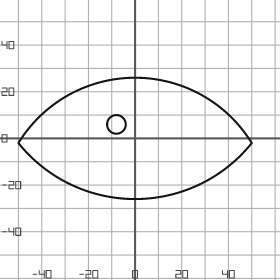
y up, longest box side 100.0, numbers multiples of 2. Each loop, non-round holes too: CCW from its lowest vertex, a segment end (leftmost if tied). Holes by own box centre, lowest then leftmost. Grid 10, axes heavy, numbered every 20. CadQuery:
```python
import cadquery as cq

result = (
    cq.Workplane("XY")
    .moveTo(-50.0, -2.0)
    .threePointArc((0.0, -26.0), (50.0, -2.0))
    .threePointArc((0.0, 26.0), (-50.0, -2.0))
    .close()
    .moveTo(-8.0, 6.0)
    .circle(4.0)
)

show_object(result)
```